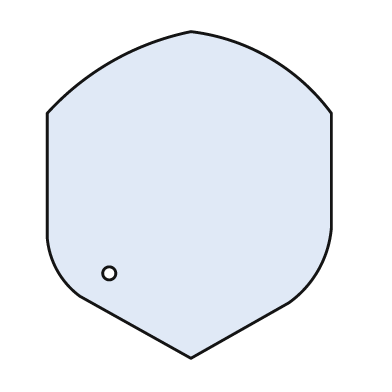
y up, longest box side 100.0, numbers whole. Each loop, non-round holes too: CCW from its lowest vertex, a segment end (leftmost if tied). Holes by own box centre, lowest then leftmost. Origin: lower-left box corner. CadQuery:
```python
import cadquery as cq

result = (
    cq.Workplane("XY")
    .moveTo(44.0, 0.0)
    .lineTo(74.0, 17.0)
    .threePointArc((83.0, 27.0), (87.0, 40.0))
    .lineTo(87.0, 75.0)
    .threePointArc((68.0, 92.0), (44.0, 100.0))
    .threePointArc((20.0, 91.0), (0.0, 75.0))
    .lineTo(0.0, 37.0)
    .threePointArc((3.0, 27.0), (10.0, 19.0))
    .close()
    .moveTo(19.0, 26.0)
    .circle(2.0)
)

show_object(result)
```